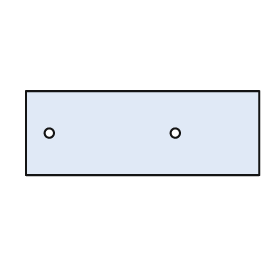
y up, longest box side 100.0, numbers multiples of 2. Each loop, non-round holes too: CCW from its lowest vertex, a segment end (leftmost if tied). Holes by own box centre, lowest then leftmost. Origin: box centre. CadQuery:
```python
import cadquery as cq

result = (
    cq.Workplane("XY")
    .moveTo(-50.0, -18.0)
    .lineTo(50.0, -18.0)
    .lineTo(50.0, 18.0)
    .lineTo(-50.0, 18.0)
    .close()
    .moveTo(-40.0, 0.0)
    .circle(2.0)
    .moveTo(14.0, 0.0)
    .circle(2.0)
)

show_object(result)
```